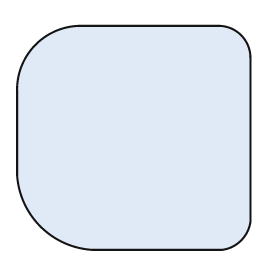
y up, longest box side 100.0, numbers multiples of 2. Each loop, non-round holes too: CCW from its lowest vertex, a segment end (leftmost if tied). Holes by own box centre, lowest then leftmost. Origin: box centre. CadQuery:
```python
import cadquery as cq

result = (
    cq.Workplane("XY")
    .moveTo(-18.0, -48.0)
    .lineTo(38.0, -48.0)
    .threePointArc((46.0, -44.0), (50.0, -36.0))
    .lineTo(50.0, 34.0)
    .threePointArc((46.0, 44.0), (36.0, 48.0))
    .lineTo(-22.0, 48.0)
    .threePointArc((-42.0, 40.0), (-50.0, 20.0))
    .lineTo(-50.0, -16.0)
    .threePointArc((-40.0, -38.0), (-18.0, -48.0))
    .close()
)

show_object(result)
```